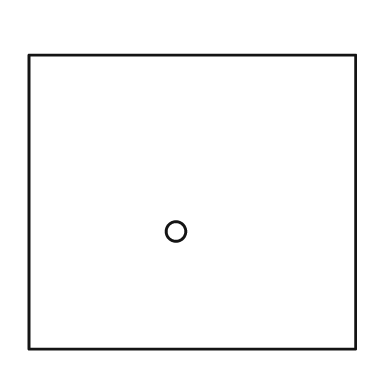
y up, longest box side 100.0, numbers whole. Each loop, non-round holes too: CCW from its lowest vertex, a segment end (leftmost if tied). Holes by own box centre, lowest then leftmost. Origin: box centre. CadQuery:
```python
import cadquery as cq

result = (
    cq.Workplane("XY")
    .moveTo(-50.0, -45.0)
    .lineTo(50.0, -45.0)
    .lineTo(50.0, 45.0)
    .lineTo(-50.0, 45.0)
    .close()
    .moveTo(-5.0, -9.0)
    .circle(3.0)
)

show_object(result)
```